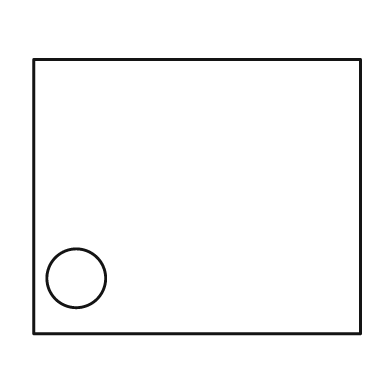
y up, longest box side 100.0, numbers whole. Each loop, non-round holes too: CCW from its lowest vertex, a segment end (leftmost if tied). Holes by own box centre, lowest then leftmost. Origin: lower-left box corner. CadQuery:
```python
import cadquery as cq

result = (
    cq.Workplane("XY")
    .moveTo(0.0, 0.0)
    .lineTo(100.0, 0.0)
    .lineTo(100.0, 84.0)
    .lineTo(0.0, 84.0)
    .close()
    .moveTo(13.0, 17.0)
    .circle(9.0)
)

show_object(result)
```